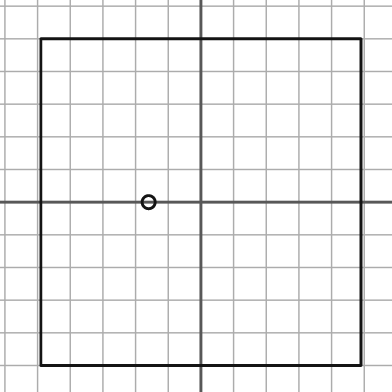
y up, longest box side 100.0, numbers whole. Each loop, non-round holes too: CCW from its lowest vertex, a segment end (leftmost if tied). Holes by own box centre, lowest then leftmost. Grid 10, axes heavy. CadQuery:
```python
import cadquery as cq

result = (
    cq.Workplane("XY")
    .moveTo(-49.0, -50.0)
    .lineTo(49.0, -50.0)
    .lineTo(49.0, 50.0)
    .lineTo(-49.0, 50.0)
    .close()
    .moveTo(-16.0, 0.0)
    .circle(2.0)
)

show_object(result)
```